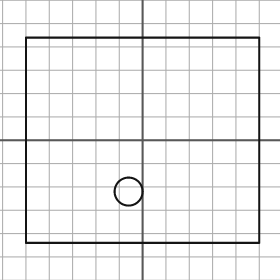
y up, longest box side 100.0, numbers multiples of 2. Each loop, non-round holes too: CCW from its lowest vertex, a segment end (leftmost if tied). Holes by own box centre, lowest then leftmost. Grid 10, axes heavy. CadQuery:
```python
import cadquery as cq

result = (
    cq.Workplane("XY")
    .moveTo(-50.0, -44.0)
    .lineTo(50.0, -44.0)
    .lineTo(50.0, 44.0)
    .lineTo(-50.0, 44.0)
    .close()
    .moveTo(-6.0, -22.0)
    .circle(6.0)
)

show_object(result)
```